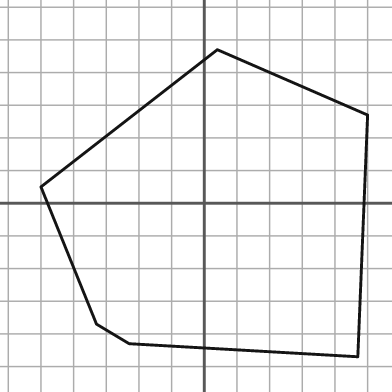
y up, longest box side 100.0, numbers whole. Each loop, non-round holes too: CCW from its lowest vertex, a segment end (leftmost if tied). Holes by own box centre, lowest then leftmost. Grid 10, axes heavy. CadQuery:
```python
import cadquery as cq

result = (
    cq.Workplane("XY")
    .moveTo(47.0, -47.0)
    .lineTo(50.0, 27.0)
    .lineTo(4.0, 47.0)
    .lineTo(-50.0, 5.0)
    .lineTo(-33.0, -37.0)
    .lineTo(-23.0, -43.0)
    .close()
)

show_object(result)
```